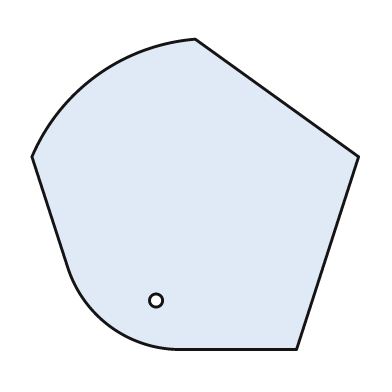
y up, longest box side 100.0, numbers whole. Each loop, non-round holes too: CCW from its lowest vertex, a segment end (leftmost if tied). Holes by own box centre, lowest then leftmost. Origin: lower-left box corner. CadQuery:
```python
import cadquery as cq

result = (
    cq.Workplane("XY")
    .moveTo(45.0, 0.0)
    .lineTo(81.0, 0.0)
    .lineTo(100.0, 59.0)
    .lineTo(50.0, 95.0)
    .threePointArc((20.0, 84.0), (0.0, 59.0))
    .lineTo(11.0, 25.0)
    .threePointArc((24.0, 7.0), (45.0, 0.0))
    .close()
    .moveTo(38.0, 15.0)
    .circle(2.0)
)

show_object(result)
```